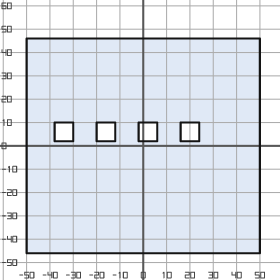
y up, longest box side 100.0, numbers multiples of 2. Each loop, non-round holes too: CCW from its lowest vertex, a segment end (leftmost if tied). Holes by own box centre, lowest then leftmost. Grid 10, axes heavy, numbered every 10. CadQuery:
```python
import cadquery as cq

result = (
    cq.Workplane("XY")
    .moveTo(-50.0, -46.0)
    .lineTo(50.0, -46.0)
    .lineTo(50.0, 46.0)
    .lineTo(-50.0, 46.0)
    .close()
    .moveTo(-38.0, 2.0)
    .lineTo(-30.0, 2.0)
    .lineTo(-30.0, 10.0)
    .lineTo(-38.0, 10.0)
    .close()
    .moveTo(-20.0, 2.0)
    .lineTo(-12.0, 2.0)
    .lineTo(-12.0, 10.0)
    .lineTo(-20.0, 10.0)
    .close()
    .moveTo(-2.0, 2.0)
    .lineTo(6.0, 2.0)
    .lineTo(6.0, 10.0)
    .lineTo(-2.0, 10.0)
    .close()
    .moveTo(16.0, 2.0)
    .lineTo(24.0, 2.0)
    .lineTo(24.0, 10.0)
    .lineTo(16.0, 10.0)
    .close()
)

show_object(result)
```